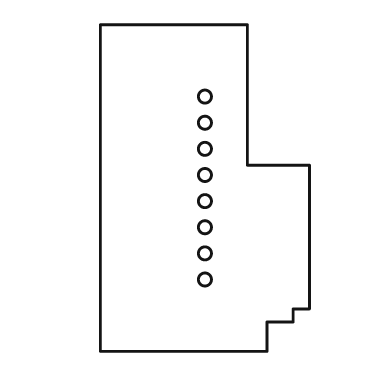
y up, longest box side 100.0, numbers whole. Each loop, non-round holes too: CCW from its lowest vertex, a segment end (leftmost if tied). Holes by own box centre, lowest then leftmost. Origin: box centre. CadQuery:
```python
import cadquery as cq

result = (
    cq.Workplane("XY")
    .moveTo(-32.0, -50.0)
    .lineTo(19.0, -50.0)
    .lineTo(19.0, -41.0)
    .lineTo(27.0, -41.0)
    .lineTo(27.0, -37.0)
    .lineTo(32.0, -37.0)
    .lineTo(32.0, 7.0)
    .lineTo(13.0, 7.0)
    .lineTo(13.0, 50.0)
    .lineTo(-32.0, 50.0)
    .close()
    .moveTo(0.0, -28.0)
    .circle(2.0)
    .moveTo(0.0, -20.0)
    .circle(2.0)
    .moveTo(0.0, -12.0)
    .circle(2.0)
    .moveTo(0.0, -4.0)
    .circle(2.0)
    .moveTo(0.0, 4.0)
    .circle(2.0)
    .moveTo(0.0, 12.0)
    .circle(2.0)
    .moveTo(0.0, 20.0)
    .circle(2.0)
    .moveTo(0.0, 28.0)
    .circle(2.0)
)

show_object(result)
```